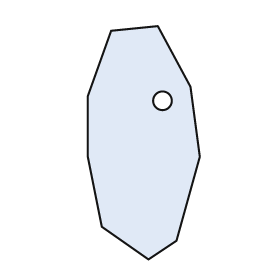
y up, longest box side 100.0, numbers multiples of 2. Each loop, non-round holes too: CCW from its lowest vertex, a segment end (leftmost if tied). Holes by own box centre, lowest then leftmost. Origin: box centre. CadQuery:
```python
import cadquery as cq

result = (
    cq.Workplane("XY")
    .moveTo(2.0, -50.0)
    .lineTo(14.0, -42.0)
    .lineTo(24.0, -6.0)
    .lineTo(20.0, 24.0)
    .lineTo(6.0, 50.0)
    .lineTo(-14.0, 48.0)
    .lineTo(-24.0, 20.0)
    .lineTo(-24.0, -6.0)
    .lineTo(-18.0, -36.0)
    .close()
    .moveTo(8.0, 18.0)
    .circle(4.0)
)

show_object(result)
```